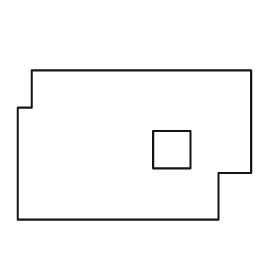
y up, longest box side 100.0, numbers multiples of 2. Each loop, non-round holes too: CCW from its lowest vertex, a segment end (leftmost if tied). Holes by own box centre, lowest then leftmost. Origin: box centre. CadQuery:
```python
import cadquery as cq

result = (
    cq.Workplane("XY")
    .moveTo(-50.0, -32.0)
    .lineTo(36.0, -32.0)
    .lineTo(36.0, -12.0)
    .lineTo(50.0, -12.0)
    .lineTo(50.0, 32.0)
    .lineTo(-44.0, 32.0)
    .lineTo(-44.0, 16.0)
    .lineTo(-50.0, 16.0)
    .close()
    .moveTo(8.0, -10.0)
    .lineTo(24.0, -10.0)
    .lineTo(24.0, 6.0)
    .lineTo(8.0, 6.0)
    .close()
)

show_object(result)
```